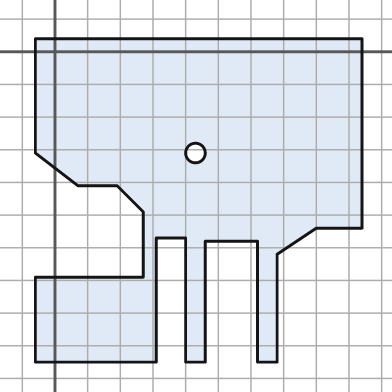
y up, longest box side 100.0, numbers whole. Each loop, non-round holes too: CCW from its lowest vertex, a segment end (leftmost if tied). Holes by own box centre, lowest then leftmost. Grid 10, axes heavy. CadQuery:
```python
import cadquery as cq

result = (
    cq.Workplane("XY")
    .moveTo(-6.0, -95.0)
    .lineTo(31.0, -95.0)
    .lineTo(31.0, -57.0)
    .lineTo(40.0, -57.0)
    .lineTo(40.0, -95.0)
    .lineTo(46.0, -95.0)
    .lineTo(46.0, -58.0)
    .lineTo(62.0, -58.0)
    .lineTo(62.0, -95.0)
    .lineTo(68.0, -95.0)
    .lineTo(68.0, -62.0)
    .lineTo(80.0, -54.0)
    .lineTo(94.0, -54.0)
    .lineTo(94.0, 4.0)
    .lineTo(-6.0, 4.0)
    .lineTo(-6.0, -31.0)
    .lineTo(7.0, -41.0)
    .lineTo(19.0, -41.0)
    .lineTo(27.0, -49.0)
    .lineTo(27.0, -69.0)
    .lineTo(-6.0, -69.0)
    .close()
    .moveTo(43.0, -31.0)
    .circle(3.0)
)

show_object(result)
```